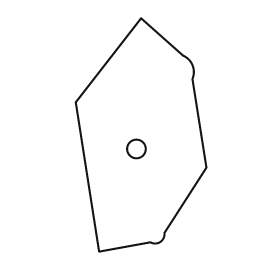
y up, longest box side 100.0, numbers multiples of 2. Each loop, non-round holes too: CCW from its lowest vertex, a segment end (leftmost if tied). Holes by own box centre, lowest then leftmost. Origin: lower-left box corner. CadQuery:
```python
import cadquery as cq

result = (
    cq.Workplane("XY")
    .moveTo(10.0, 0.0)
    .lineTo(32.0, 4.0)
    .threePointArc((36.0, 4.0), (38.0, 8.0))
    .lineTo(56.0, 36.0)
    .lineTo(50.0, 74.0)
    .threePointArc((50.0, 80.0), (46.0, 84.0))
    .lineTo(28.0, 100.0)
    .lineTo(0.0, 64.0)
    .close()
    .moveTo(26.0, 44.0)
    .circle(4.0)
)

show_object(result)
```